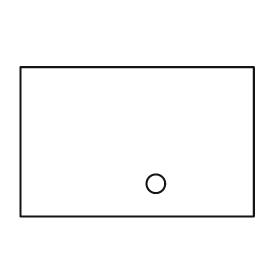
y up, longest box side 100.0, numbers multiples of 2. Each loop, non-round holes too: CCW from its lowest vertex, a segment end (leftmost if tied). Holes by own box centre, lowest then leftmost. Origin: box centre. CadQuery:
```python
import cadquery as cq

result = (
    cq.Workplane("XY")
    .moveTo(-50.0, -32.0)
    .lineTo(50.0, -32.0)
    .lineTo(50.0, 32.0)
    .lineTo(-50.0, 32.0)
    .close()
    .moveTo(8.0, -18.0)
    .circle(4.0)
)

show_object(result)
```